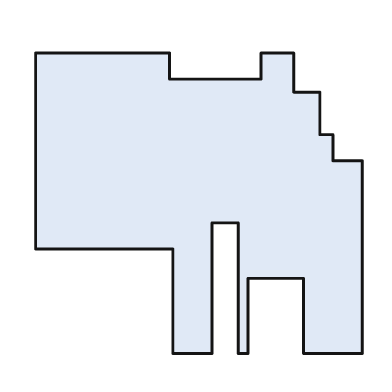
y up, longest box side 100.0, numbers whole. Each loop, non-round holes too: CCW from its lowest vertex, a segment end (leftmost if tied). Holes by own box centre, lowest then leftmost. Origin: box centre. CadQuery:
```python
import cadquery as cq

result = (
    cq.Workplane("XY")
    .moveTo(-8.0, -46.0)
    .lineTo(4.0, -46.0)
    .lineTo(4.0, -6.0)
    .lineTo(12.0, -6.0)
    .lineTo(12.0, -46.0)
    .lineTo(15.0, -46.0)
    .lineTo(15.0, -23.0)
    .lineTo(32.0, -23.0)
    .lineTo(32.0, -46.0)
    .lineTo(50.0, -46.0)
    .lineTo(50.0, 13.0)
    .lineTo(41.0, 13.0)
    .lineTo(41.0, 21.0)
    .lineTo(37.0, 21.0)
    .lineTo(37.0, 34.0)
    .lineTo(29.0, 34.0)
    .lineTo(29.0, 46.0)
    .lineTo(19.0, 46.0)
    .lineTo(19.0, 38.0)
    .lineTo(-9.0, 38.0)
    .lineTo(-9.0, 46.0)
    .lineTo(-50.0, 46.0)
    .lineTo(-50.0, -14.0)
    .lineTo(-8.0, -14.0)
    .close()
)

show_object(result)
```